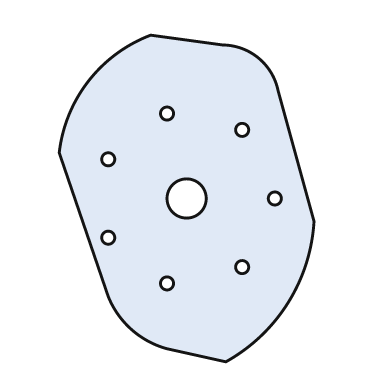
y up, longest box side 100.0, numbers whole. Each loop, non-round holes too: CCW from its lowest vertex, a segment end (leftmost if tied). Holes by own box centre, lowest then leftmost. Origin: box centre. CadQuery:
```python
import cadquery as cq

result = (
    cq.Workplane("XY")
    .moveTo(12.0, -50.0)
    .threePointArc((31.0, -32.0), (39.0, -7.0))
    .lineTo(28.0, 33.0)
    .threePointArc((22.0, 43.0), (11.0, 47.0))
    .lineTo(-11.0, 50.0)
    .threePointArc((-30.0, 36.0), (-39.0, 14.0))
    .lineTo(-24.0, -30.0)
    .threePointArc((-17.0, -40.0), (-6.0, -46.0))
    .close()
    .moveTo(-6.0, -26.0)
    .circle(2.0)
    .moveTo(17.0, -21.0)
    .circle(2.0)
    .moveTo(-24.0, -12.0)
    .circle(2.0)
    .moveTo(0.0, 0.0)
    .circle(6.0)
    .moveTo(27.0, 0.0)
    .circle(2.0)
    .moveTo(-24.0, 12.0)
    .circle(2.0)
    .moveTo(17.0, 21.0)
    .circle(2.0)
    .moveTo(-6.0, 26.0)
    .circle(2.0)
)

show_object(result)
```